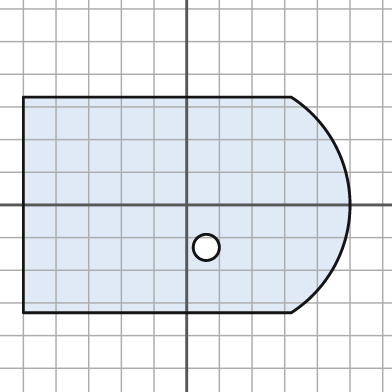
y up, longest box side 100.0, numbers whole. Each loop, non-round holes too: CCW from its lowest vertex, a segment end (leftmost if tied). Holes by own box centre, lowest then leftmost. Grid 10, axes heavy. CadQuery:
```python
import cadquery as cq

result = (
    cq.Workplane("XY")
    .moveTo(-50.0, -33.0)
    .lineTo(32.0, -33.0)
    .threePointArc((50.0, 0.0), (32.0, 33.0))
    .lineTo(-50.0, 33.0)
    .close()
    .moveTo(6.0, -13.0)
    .circle(4.0)
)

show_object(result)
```